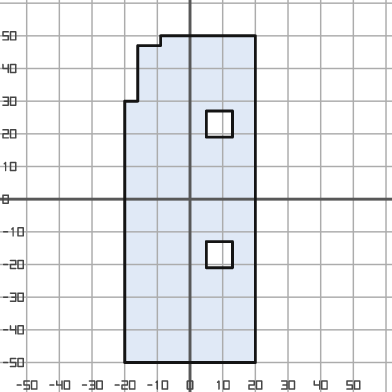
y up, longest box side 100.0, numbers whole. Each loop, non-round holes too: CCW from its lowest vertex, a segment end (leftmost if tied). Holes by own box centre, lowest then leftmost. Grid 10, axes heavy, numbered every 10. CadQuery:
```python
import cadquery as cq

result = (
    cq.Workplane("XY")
    .moveTo(-20.0, -50.0)
    .lineTo(20.0, -50.0)
    .lineTo(20.0, 50.0)
    .lineTo(-9.0, 50.0)
    .lineTo(-9.0, 47.0)
    .lineTo(-16.0, 47.0)
    .lineTo(-16.0, 30.0)
    .lineTo(-20.0, 30.0)
    .close()
    .moveTo(5.0, -21.0)
    .lineTo(13.0, -21.0)
    .lineTo(13.0, -13.0)
    .lineTo(5.0, -13.0)
    .close()
    .moveTo(5.0, 19.0)
    .lineTo(13.0, 19.0)
    .lineTo(13.0, 27.0)
    .lineTo(5.0, 27.0)
    .close()
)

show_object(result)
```